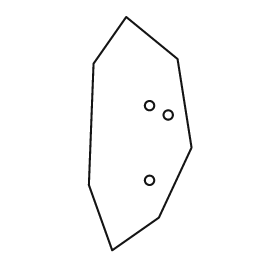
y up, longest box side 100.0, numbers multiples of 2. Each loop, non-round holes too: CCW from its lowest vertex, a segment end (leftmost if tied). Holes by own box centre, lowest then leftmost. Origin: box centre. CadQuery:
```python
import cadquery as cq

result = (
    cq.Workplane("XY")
    .moveTo(-12.0, -50.0)
    .lineTo(8.0, -36.0)
    .lineTo(22.0, -6.0)
    .lineTo(16.0, 32.0)
    .lineTo(-6.0, 50.0)
    .lineTo(-20.0, 30.0)
    .lineTo(-22.0, -22.0)
    .close()
    .moveTo(4.0, -20.0)
    .circle(2.0)
    .moveTo(12.0, 8.0)
    .circle(2.0)
    .moveTo(4.0, 12.0)
    .circle(2.0)
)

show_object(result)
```